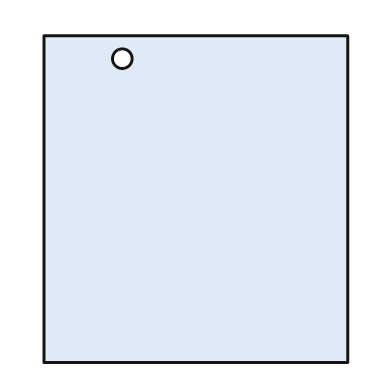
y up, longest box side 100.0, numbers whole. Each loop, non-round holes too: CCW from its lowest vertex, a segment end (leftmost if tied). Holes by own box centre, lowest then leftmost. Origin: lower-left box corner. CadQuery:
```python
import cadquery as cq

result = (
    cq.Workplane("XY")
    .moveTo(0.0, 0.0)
    .lineTo(93.0, 0.0)
    .lineTo(93.0, 100.0)
    .lineTo(0.0, 100.0)
    .close()
    .moveTo(24.0, 93.0)
    .circle(3.0)
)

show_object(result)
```